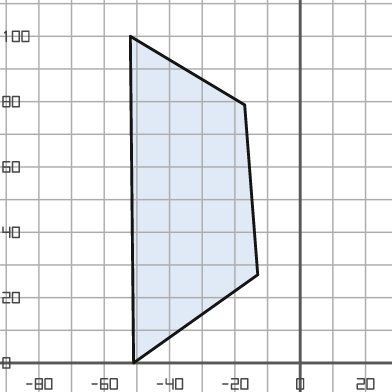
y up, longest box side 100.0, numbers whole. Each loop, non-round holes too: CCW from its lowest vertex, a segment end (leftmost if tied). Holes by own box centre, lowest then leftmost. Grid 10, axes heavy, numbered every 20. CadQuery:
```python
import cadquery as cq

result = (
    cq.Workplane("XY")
    .moveTo(-51.0, 0.0)
    .lineTo(-13.0, 27.0)
    .lineTo(-17.0, 79.0)
    .lineTo(-52.0, 100.0)
    .close()
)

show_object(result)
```